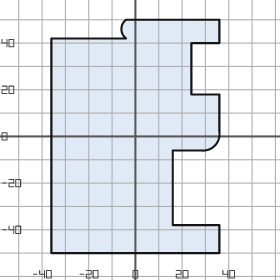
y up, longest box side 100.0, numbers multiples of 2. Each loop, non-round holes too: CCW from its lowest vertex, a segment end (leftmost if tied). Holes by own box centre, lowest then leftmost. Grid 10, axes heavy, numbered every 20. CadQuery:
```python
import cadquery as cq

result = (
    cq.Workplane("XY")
    .moveTo(-36.0, -50.0)
    .lineTo(36.0, -50.0)
    .lineTo(36.0, -38.0)
    .lineTo(16.0, -38.0)
    .lineTo(16.0, -6.0)
    .lineTo(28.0, -6.0)
    .threePointArc((34.0, -4.0), (36.0, 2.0))
    .lineTo(36.0, 18.0)
    .lineTo(24.0, 18.0)
    .lineTo(24.0, 40.0)
    .lineTo(36.0, 40.0)
    .lineTo(36.0, 50.0)
    .lineTo(-4.0, 50.0)
    .threePointArc((-6.0, 46.0), (-4.0, 42.0))
    .lineTo(-36.0, 42.0)
    .close()
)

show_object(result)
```